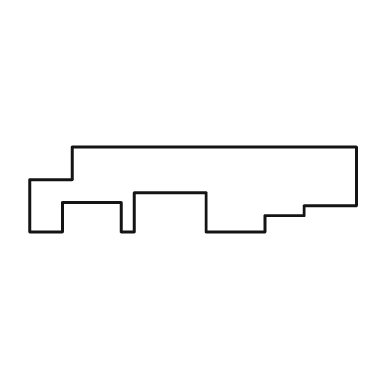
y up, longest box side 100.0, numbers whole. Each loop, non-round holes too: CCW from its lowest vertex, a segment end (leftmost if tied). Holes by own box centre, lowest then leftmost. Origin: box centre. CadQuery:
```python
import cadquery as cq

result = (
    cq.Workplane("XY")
    .moveTo(-50.0, -13.0)
    .lineTo(-40.0, -13.0)
    .lineTo(-40.0, -4.0)
    .lineTo(-22.0, -4.0)
    .lineTo(-22.0, -13.0)
    .lineTo(-18.0, -13.0)
    .lineTo(-18.0, -1.0)
    .lineTo(4.0, -1.0)
    .lineTo(4.0, -13.0)
    .lineTo(22.0, -13.0)
    .lineTo(22.0, -8.0)
    .lineTo(34.0, -8.0)
    .lineTo(34.0, -5.0)
    .lineTo(50.0, -5.0)
    .lineTo(50.0, 13.0)
    .lineTo(-37.0, 13.0)
    .lineTo(-37.0, 3.0)
    .lineTo(-50.0, 3.0)
    .close()
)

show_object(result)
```